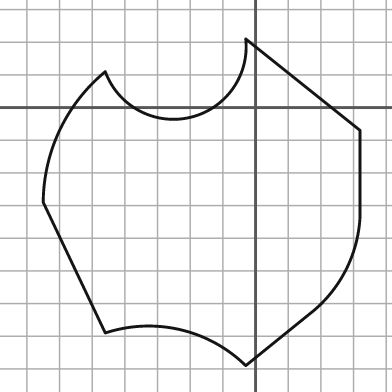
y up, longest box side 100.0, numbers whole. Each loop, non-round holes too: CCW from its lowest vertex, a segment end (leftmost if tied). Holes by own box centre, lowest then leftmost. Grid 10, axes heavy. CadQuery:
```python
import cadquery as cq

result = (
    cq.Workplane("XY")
    .moveTo(-3.0, -79.0)
    .lineTo(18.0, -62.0)
    .threePointArc((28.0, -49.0), (32.0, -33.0))
    .lineTo(32.0, -7.0)
    .lineTo(-3.0, 21.0)
    .threePointArc((-20.0, -3.0), (-46.0, 11.0))
    .threePointArc((-60.0, -7.0), (-65.0, -29.0))
    .lineTo(-46.0, -69.0)
    .threePointArc((-23.0, -68.0), (-3.0, -79.0))
    .close()
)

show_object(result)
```